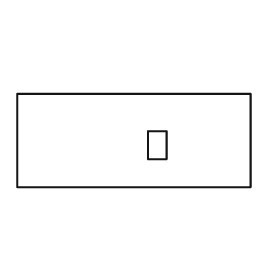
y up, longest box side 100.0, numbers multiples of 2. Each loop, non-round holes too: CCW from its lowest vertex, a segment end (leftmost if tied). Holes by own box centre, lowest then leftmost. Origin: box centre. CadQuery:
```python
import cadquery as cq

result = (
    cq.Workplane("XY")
    .moveTo(-50.0, -20.0)
    .lineTo(50.0, -20.0)
    .lineTo(50.0, 20.0)
    .lineTo(-50.0, 20.0)
    .close()
    .moveTo(6.0, -8.0)
    .lineTo(14.0, -8.0)
    .lineTo(14.0, 4.0)
    .lineTo(6.0, 4.0)
    .close()
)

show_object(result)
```